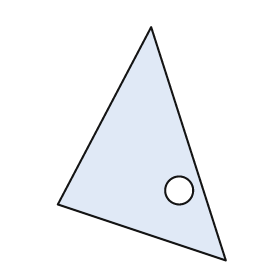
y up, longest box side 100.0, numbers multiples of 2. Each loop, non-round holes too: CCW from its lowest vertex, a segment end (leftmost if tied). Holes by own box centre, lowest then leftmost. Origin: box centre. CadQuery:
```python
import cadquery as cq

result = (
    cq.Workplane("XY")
    .moveTo(36.0, -50.0)
    .lineTo(4.0, 50.0)
    .lineTo(-36.0, -26.0)
    .close()
    .moveTo(16.0, -20.0)
    .circle(6.0)
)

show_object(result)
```